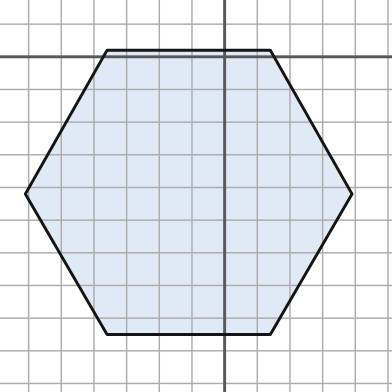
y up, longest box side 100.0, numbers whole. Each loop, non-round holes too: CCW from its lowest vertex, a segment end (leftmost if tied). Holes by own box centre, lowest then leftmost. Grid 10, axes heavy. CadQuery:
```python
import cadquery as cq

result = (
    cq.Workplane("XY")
    .moveTo(-36.0, -85.0)
    .lineTo(14.0, -85.0)
    .lineTo(39.0, -42.0)
    .lineTo(14.0, 2.0)
    .lineTo(-36.0, 2.0)
    .lineTo(-61.0, -42.0)
    .close()
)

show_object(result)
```